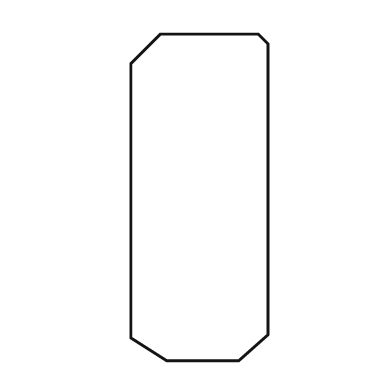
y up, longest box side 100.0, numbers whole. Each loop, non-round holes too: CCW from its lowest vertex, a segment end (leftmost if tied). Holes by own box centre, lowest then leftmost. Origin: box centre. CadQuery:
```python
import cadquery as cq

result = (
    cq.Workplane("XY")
    .moveTo(-10.0, -50.0)
    .lineTo(12.0, -50.0)
    .lineTo(21.0, -42.0)
    .lineTo(21.0, 47.0)
    .lineTo(18.0, 50.0)
    .lineTo(-12.0, 50.0)
    .lineTo(-21.0, 41.0)
    .lineTo(-21.0, -43.0)
    .close()
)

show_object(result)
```